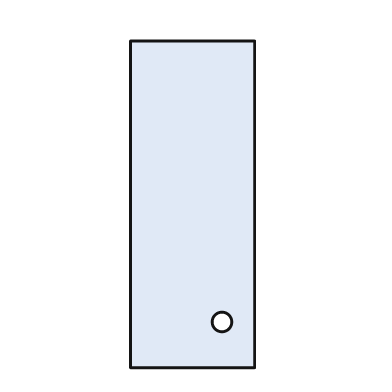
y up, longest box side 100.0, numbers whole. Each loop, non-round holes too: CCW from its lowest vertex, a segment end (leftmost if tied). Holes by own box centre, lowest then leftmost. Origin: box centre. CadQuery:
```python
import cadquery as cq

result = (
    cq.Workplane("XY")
    .moveTo(-19.0, -50.0)
    .lineTo(19.0, -50.0)
    .lineTo(19.0, 50.0)
    .lineTo(-19.0, 50.0)
    .close()
    .moveTo(9.0, -36.0)
    .circle(3.0)
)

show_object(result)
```